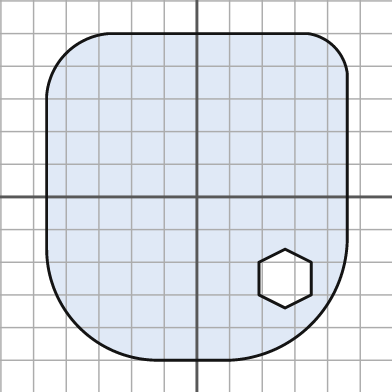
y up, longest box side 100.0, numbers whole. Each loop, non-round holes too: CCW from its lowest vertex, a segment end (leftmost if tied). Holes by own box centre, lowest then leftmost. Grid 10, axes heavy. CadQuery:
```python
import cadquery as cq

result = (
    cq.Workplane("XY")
    .moveTo(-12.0, -50.0)
    .lineTo(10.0, -50.0)
    .threePointArc((35.0, -39.0), (46.0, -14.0))
    .lineTo(46.0, 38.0)
    .threePointArc((42.0, 46.0), (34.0, 50.0))
    .lineTo(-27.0, 50.0)
    .threePointArc((-40.0, 44.0), (-46.0, 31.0))
    .lineTo(-46.0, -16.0)
    .threePointArc((-36.0, -40.0), (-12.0, -50.0))
    .close()
    .moveTo(27.0, -34.0)
    .lineTo(35.0, -30.0)
    .lineTo(35.0, -20.0)
    .lineTo(27.0, -16.0)
    .lineTo(19.0, -20.0)
    .lineTo(19.0, -30.0)
    .close()
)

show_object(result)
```